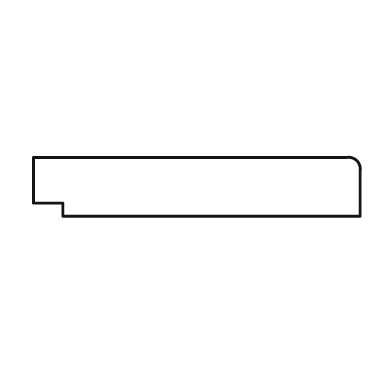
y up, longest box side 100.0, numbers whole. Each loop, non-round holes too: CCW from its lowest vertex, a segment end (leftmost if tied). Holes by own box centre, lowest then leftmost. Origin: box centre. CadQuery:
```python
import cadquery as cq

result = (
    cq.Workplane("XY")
    .moveTo(-41.0, -9.0)
    .lineTo(50.0, -9.0)
    .lineTo(50.0, 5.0)
    .threePointArc((49.0, 8.0), (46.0, 9.0))
    .lineTo(-50.0, 9.0)
    .lineTo(-50.0, -5.0)
    .lineTo(-41.0, -5.0)
    .close()
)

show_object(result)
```